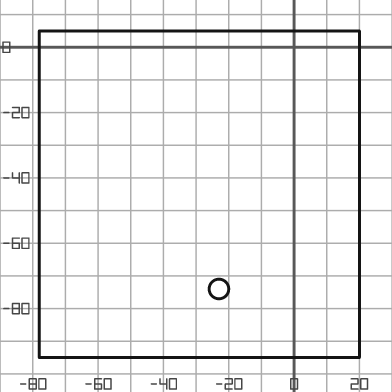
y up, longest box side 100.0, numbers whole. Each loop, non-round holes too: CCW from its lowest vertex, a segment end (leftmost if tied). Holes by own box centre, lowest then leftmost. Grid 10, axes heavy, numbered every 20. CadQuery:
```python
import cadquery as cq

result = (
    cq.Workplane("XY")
    .moveTo(-78.0, -95.0)
    .lineTo(20.0, -95.0)
    .lineTo(20.0, 5.0)
    .lineTo(-78.0, 5.0)
    .close()
    .moveTo(-23.0, -74.0)
    .circle(3.0)
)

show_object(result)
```